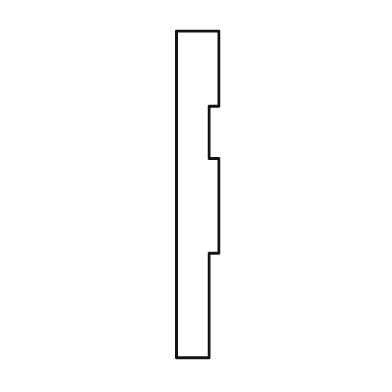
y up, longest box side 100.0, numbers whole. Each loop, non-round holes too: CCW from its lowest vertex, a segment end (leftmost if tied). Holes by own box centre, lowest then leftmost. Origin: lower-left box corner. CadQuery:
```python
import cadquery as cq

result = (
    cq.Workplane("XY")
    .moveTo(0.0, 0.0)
    .lineTo(10.0, 0.0)
    .lineTo(10.0, 32.0)
    .lineTo(13.0, 32.0)
    .lineTo(13.0, 61.0)
    .lineTo(10.0, 61.0)
    .lineTo(10.0, 77.0)
    .lineTo(13.0, 77.0)
    .lineTo(13.0, 100.0)
    .lineTo(0.0, 100.0)
    .close()
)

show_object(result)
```